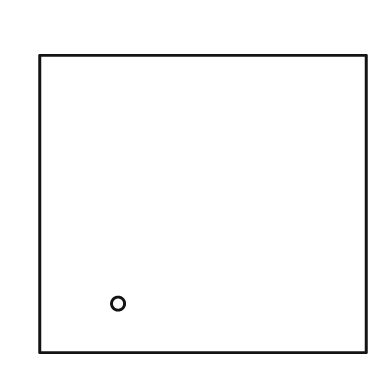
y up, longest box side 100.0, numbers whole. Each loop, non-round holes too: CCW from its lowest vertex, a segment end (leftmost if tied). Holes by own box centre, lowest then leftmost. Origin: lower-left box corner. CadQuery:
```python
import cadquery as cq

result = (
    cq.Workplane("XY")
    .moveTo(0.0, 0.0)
    .lineTo(100.0, 0.0)
    .lineTo(100.0, 91.0)
    .lineTo(0.0, 91.0)
    .close()
    .moveTo(24.0, 15.0)
    .circle(2.0)
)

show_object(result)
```